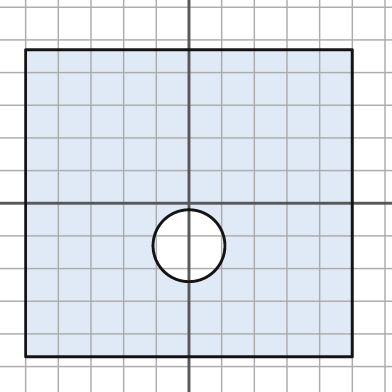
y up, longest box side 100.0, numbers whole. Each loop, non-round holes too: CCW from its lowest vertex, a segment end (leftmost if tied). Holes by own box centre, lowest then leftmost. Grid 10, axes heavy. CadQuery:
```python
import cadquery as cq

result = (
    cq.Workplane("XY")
    .moveTo(-50.0, -47.0)
    .lineTo(50.0, -47.0)
    .lineTo(50.0, 47.0)
    .lineTo(-50.0, 47.0)
    .close()
    .moveTo(0.0, -13.0)
    .circle(11.0)
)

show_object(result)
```